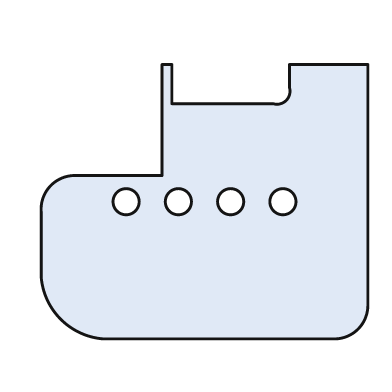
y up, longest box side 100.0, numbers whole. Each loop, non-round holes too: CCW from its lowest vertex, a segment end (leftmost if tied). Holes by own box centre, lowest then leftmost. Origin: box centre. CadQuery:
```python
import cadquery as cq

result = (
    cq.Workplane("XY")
    .moveTo(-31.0, -42.0)
    .lineTo(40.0, -42.0)
    .threePointArc((47.0, -39.0), (50.0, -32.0))
    .lineTo(50.0, 42.0)
    .lineTo(26.0, 42.0)
    .lineTo(26.0, 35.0)
    .threePointArc((25.0, 31.0), (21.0, 30.0))
    .lineTo(-10.0, 30.0)
    .lineTo(-10.0, 42.0)
    .lineTo(-13.0, 42.0)
    .lineTo(-13.0, 8.0)
    .lineTo(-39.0, 8.0)
    .threePointArc((-47.0, 5.0), (-50.0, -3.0))
    .lineTo(-50.0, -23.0)
    .threePointArc((-44.0, -36.0), (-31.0, -42.0))
    .close()
    .moveTo(-24.0, 0.0)
    .circle(4.0)
    .moveTo(-8.0, 0.0)
    .circle(4.0)
    .moveTo(8.0, 0.0)
    .circle(4.0)
    .moveTo(24.0, 0.0)
    .circle(4.0)
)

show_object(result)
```